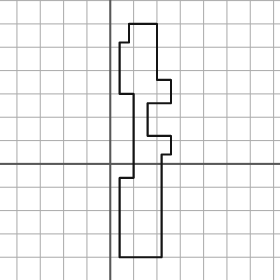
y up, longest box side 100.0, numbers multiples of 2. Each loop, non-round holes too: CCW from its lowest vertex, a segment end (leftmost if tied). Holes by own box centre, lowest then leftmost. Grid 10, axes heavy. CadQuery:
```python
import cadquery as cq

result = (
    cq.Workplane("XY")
    .moveTo(4.0, -40.0)
    .lineTo(22.0, -40.0)
    .lineTo(22.0, 4.0)
    .lineTo(26.0, 4.0)
    .lineTo(26.0, 12.0)
    .lineTo(16.0, 12.0)
    .lineTo(16.0, 26.0)
    .lineTo(26.0, 26.0)
    .lineTo(26.0, 36.0)
    .lineTo(20.0, 36.0)
    .lineTo(20.0, 60.0)
    .lineTo(8.0, 60.0)
    .lineTo(8.0, 52.0)
    .lineTo(4.0, 52.0)
    .lineTo(4.0, 30.0)
    .lineTo(10.0, 30.0)
    .lineTo(10.0, -6.0)
    .lineTo(4.0, -6.0)
    .close()
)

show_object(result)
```